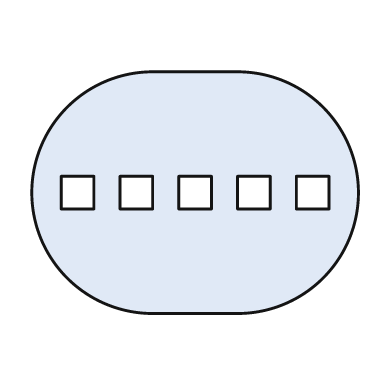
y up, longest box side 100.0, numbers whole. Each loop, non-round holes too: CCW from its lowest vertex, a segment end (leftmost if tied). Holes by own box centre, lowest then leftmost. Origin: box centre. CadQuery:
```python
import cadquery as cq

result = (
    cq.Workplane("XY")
    .moveTo(-13.0, -37.0)
    .lineTo(13.0, -37.0)
    .threePointArc((50.0, 0.0), (13.0, 37.0))
    .lineTo(-13.0, 37.0)
    .threePointArc((-50.0, 0.0), (-13.0, -37.0))
    .close()
    .moveTo(-41.0, -5.0)
    .lineTo(-31.0, -5.0)
    .lineTo(-31.0, 5.0)
    .lineTo(-41.0, 5.0)
    .close()
    .moveTo(-23.0, -5.0)
    .lineTo(-13.0, -5.0)
    .lineTo(-13.0, 5.0)
    .lineTo(-23.0, 5.0)
    .close()
    .moveTo(-5.0, -5.0)
    .lineTo(5.0, -5.0)
    .lineTo(5.0, 5.0)
    .lineTo(-5.0, 5.0)
    .close()
    .moveTo(13.0, -5.0)
    .lineTo(23.0, -5.0)
    .lineTo(23.0, 5.0)
    .lineTo(13.0, 5.0)
    .close()
    .moveTo(31.0, -5.0)
    .lineTo(41.0, -5.0)
    .lineTo(41.0, 5.0)
    .lineTo(31.0, 5.0)
    .close()
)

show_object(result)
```